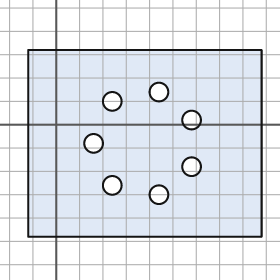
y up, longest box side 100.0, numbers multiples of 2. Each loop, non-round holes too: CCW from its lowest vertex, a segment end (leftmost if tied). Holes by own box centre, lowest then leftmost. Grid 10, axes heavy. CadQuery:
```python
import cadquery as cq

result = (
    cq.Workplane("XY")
    .moveTo(-12.0, -48.0)
    .lineTo(88.0, -48.0)
    .lineTo(88.0, 32.0)
    .lineTo(-12.0, 32.0)
    .close()
    .moveTo(44.0, -30.0)
    .circle(4.0)
    .moveTo(24.0, -26.0)
    .circle(4.0)
    .moveTo(58.0, -18.0)
    .circle(4.0)
    .moveTo(16.0, -8.0)
    .circle(4.0)
    .moveTo(58.0, 2.0)
    .circle(4.0)
    .moveTo(24.0, 10.0)
    .circle(4.0)
    .moveTo(44.0, 14.0)
    .circle(4.0)
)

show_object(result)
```